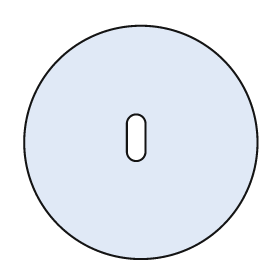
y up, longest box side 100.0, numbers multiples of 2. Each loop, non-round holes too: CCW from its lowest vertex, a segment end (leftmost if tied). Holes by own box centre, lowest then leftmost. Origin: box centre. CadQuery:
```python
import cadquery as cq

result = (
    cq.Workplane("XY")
    .moveTo(0.0, 0.0)
    .circle(50.0)
    .moveTo(-6.0, -4.0)
    .threePointArc((-2.0, -8.0), (2.0, -4.0))
    .lineTo(2.0, 8.0)
    .threePointArc((-2.0, 12.0), (-6.0, 8.0))
    .close()
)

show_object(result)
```